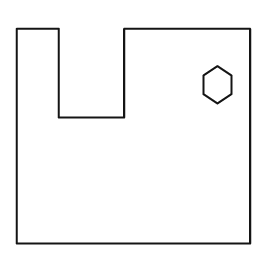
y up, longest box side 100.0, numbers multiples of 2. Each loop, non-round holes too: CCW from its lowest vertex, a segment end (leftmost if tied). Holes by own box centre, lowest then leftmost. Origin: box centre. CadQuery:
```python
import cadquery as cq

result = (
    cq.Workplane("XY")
    .moveTo(-50.0, -46.0)
    .lineTo(50.0, -46.0)
    .lineTo(50.0, 46.0)
    .lineTo(-4.0, 46.0)
    .lineTo(-4.0, 8.0)
    .lineTo(-32.0, 8.0)
    .lineTo(-32.0, 46.0)
    .lineTo(-50.0, 46.0)
    .close()
    .moveTo(36.0, 14.0)
    .lineTo(42.0, 18.0)
    .lineTo(42.0, 26.0)
    .lineTo(36.0, 30.0)
    .lineTo(30.0, 26.0)
    .lineTo(30.0, 18.0)
    .close()
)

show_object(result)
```